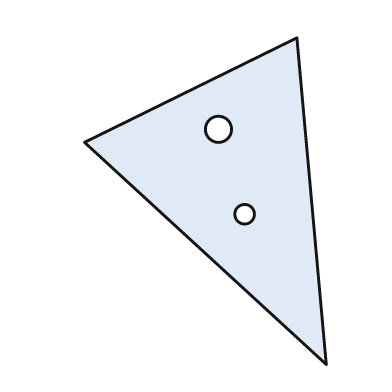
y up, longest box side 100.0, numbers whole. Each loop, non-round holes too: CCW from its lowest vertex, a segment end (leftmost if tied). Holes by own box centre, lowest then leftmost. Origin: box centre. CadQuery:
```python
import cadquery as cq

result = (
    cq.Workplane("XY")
    .moveTo(37.0, -50.0)
    .lineTo(28.0, 50.0)
    .lineTo(-37.0, 18.0)
    .close()
    .moveTo(12.0, -4.0)
    .circle(3.0)
    .moveTo(4.0, 22.0)
    .circle(4.0)
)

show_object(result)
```